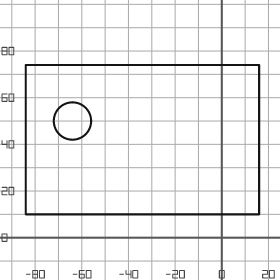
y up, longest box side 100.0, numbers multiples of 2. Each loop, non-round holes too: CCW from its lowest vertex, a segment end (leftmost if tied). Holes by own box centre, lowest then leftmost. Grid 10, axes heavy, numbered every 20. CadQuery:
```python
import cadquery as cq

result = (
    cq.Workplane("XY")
    .moveTo(-84.0, 10.0)
    .lineTo(16.0, 10.0)
    .lineTo(16.0, 74.0)
    .lineTo(-84.0, 74.0)
    .close()
    .moveTo(-64.0, 50.0)
    .circle(8.0)
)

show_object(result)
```